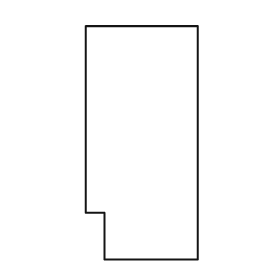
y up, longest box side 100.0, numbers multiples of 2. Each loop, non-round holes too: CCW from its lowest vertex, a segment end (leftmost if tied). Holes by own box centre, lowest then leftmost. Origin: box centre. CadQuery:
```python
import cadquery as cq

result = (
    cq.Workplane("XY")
    .moveTo(-16.0, -50.0)
    .lineTo(24.0, -50.0)
    .lineTo(24.0, 50.0)
    .lineTo(-24.0, 50.0)
    .lineTo(-24.0, -30.0)
    .lineTo(-16.0, -30.0)
    .close()
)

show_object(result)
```